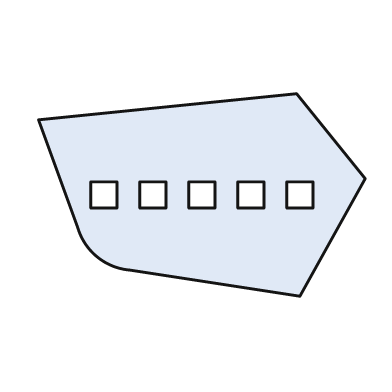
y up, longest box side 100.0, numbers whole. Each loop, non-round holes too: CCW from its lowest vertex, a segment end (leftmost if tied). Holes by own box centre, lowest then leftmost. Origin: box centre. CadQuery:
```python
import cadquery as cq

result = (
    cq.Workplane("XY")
    .moveTo(30.0, -31.0)
    .lineTo(50.0, 5.0)
    .lineTo(29.0, 31.0)
    .lineTo(-50.0, 23.0)
    .lineTo(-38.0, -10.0)
    .threePointArc((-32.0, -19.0), (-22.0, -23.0))
    .close()
    .moveTo(-34.0, -4.0)
    .lineTo(-26.0, -4.0)
    .lineTo(-26.0, 4.0)
    .lineTo(-34.0, 4.0)
    .close()
    .moveTo(-19.0, -4.0)
    .lineTo(-11.0, -4.0)
    .lineTo(-11.0, 4.0)
    .lineTo(-19.0, 4.0)
    .close()
    .moveTo(-4.0, -4.0)
    .lineTo(4.0, -4.0)
    .lineTo(4.0, 4.0)
    .lineTo(-4.0, 4.0)
    .close()
    .moveTo(11.0, -4.0)
    .lineTo(19.0, -4.0)
    .lineTo(19.0, 4.0)
    .lineTo(11.0, 4.0)
    .close()
    .moveTo(26.0, -4.0)
    .lineTo(34.0, -4.0)
    .lineTo(34.0, 4.0)
    .lineTo(26.0, 4.0)
    .close()
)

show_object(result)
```